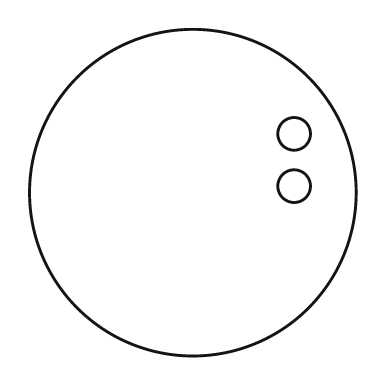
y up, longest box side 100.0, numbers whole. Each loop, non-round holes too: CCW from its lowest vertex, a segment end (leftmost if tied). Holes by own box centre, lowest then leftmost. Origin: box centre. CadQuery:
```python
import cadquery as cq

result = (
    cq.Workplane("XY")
    .moveTo(0.0, 0.0)
    .circle(50.0)
    .moveTo(31.0, 2.0)
    .circle(5.0)
    .moveTo(31.0, 18.0)
    .circle(5.0)
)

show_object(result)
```